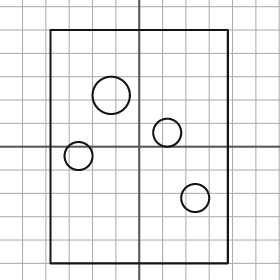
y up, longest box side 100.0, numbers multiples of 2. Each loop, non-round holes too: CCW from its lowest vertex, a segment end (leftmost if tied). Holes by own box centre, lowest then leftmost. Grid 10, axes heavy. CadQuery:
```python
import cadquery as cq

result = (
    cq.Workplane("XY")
    .moveTo(-38.0, -50.0)
    .lineTo(38.0, -50.0)
    .lineTo(38.0, 50.0)
    .lineTo(-38.0, 50.0)
    .close()
    .moveTo(24.0, -22.0)
    .circle(6.0)
    .moveTo(-26.0, -4.0)
    .circle(6.0)
    .moveTo(12.0, 6.0)
    .circle(6.0)
    .moveTo(-12.0, 22.0)
    .circle(8.0)
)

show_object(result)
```